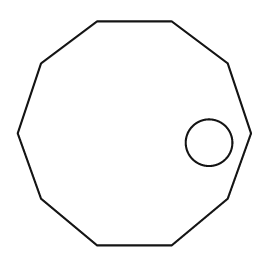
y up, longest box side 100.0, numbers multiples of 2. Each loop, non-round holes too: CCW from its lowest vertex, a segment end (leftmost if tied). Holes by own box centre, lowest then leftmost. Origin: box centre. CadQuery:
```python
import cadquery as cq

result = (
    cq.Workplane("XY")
    .moveTo(-16.0, -48.0)
    .lineTo(16.0, -48.0)
    .lineTo(40.0, -28.0)
    .lineTo(50.0, 0.0)
    .lineTo(40.0, 30.0)
    .lineTo(16.0, 48.0)
    .lineTo(-16.0, 48.0)
    .lineTo(-40.0, 30.0)
    .lineTo(-50.0, 0.0)
    .lineTo(-40.0, -28.0)
    .close()
    .moveTo(32.0, -4.0)
    .circle(10.0)
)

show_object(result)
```